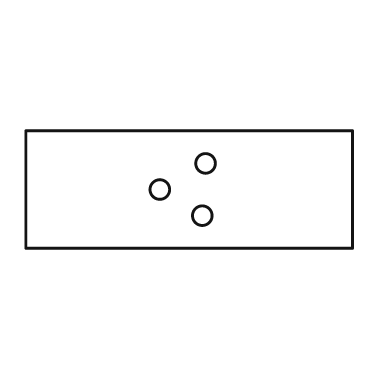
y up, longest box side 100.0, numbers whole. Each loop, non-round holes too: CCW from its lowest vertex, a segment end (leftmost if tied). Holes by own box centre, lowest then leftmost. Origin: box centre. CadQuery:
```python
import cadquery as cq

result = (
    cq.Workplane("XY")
    .moveTo(-50.0, -18.0)
    .lineTo(50.0, -18.0)
    .lineTo(50.0, 18.0)
    .lineTo(-50.0, 18.0)
    .close()
    .moveTo(4.0, -8.0)
    .circle(3.0)
    .moveTo(-9.0, 0.0)
    .circle(3.0)
    .moveTo(5.0, 8.0)
    .circle(3.0)
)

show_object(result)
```